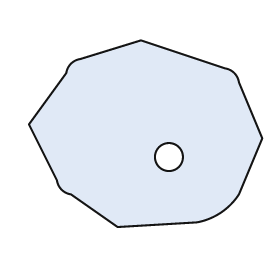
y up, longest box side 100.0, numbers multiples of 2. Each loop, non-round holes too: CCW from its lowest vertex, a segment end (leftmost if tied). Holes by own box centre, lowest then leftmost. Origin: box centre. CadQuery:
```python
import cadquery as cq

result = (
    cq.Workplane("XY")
    .moveTo(-12.0, -40.0)
    .lineTo(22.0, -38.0)
    .threePointArc((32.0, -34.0), (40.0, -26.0))
    .lineTo(50.0, -2.0)
    .lineTo(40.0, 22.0)
    .threePointArc((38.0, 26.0), (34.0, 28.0))
    .lineTo(-2.0, 40.0)
    .lineTo(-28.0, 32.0)
    .threePointArc((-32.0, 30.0), (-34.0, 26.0))
    .lineTo(-50.0, 4.0)
    .lineTo(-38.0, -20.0)
    .threePointArc((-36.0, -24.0), (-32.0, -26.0))
    .close()
    .moveTo(10.0, -10.0)
    .circle(6.0)
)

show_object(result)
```